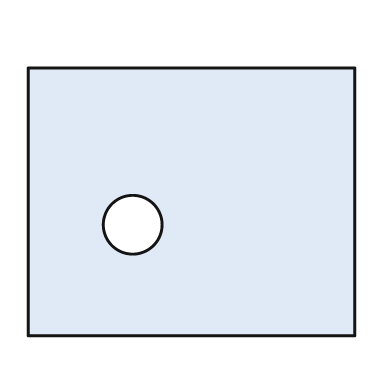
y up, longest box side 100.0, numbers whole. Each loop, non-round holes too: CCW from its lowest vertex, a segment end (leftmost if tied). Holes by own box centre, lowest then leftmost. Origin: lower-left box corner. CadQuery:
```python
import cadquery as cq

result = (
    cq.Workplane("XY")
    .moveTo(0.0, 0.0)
    .lineTo(100.0, 0.0)
    .lineTo(100.0, 82.0)
    .lineTo(0.0, 82.0)
    .close()
    .moveTo(32.0, 34.0)
    .circle(9.0)
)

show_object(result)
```